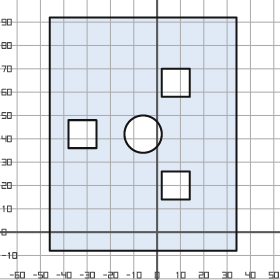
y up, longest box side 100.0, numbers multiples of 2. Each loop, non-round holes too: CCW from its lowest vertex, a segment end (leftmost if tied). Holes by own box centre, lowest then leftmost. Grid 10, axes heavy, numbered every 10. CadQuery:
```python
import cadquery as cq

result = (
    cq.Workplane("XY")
    .moveTo(-46.0, -8.0)
    .lineTo(34.0, -8.0)
    .lineTo(34.0, 92.0)
    .lineTo(-46.0, 92.0)
    .close()
    .moveTo(2.0, 14.0)
    .lineTo(14.0, 14.0)
    .lineTo(14.0, 26.0)
    .lineTo(2.0, 26.0)
    .close()
    .moveTo(-38.0, 36.0)
    .lineTo(-26.0, 36.0)
    .lineTo(-26.0, 48.0)
    .lineTo(-38.0, 48.0)
    .close()
    .moveTo(-6.0, 42.0)
    .circle(8.0)
    .moveTo(2.0, 58.0)
    .lineTo(14.0, 58.0)
    .lineTo(14.0, 70.0)
    .lineTo(2.0, 70.0)
    .close()
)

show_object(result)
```